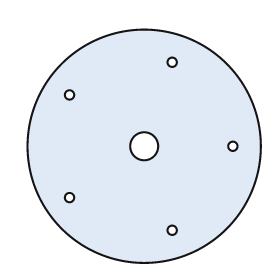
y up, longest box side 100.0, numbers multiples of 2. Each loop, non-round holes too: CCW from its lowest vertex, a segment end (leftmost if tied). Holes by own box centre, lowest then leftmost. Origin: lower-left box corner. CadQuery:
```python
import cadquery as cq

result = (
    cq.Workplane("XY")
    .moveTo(50.0, 50.0)
    .circle(50.0)
    .moveTo(62.0, 14.0)
    .circle(2.0)
    .moveTo(18.0, 28.0)
    .circle(2.0)
    .moveTo(50.0, 50.0)
    .circle(6.0)
    .moveTo(88.0, 50.0)
    .circle(2.0)
    .moveTo(18.0, 72.0)
    .circle(2.0)
    .moveTo(62.0, 86.0)
    .circle(2.0)
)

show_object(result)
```